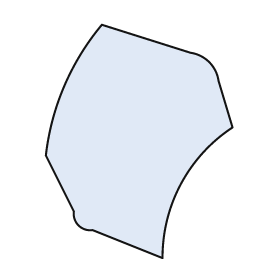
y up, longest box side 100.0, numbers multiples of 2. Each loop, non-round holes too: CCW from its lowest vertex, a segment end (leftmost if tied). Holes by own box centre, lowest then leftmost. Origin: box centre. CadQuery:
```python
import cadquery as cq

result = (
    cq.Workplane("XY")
    .moveTo(10.0, -50.0)
    .threePointArc((18.0, -18.0), (40.0, 6.0))
    .lineTo(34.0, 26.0)
    .threePointArc((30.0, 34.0), (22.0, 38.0))
    .lineTo(-16.0, 50.0)
    .threePointArc((-32.0, 24.0), (-40.0, -6.0))
    .lineTo(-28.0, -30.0)
    .threePointArc((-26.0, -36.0), (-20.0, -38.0))
    .close()
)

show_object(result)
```